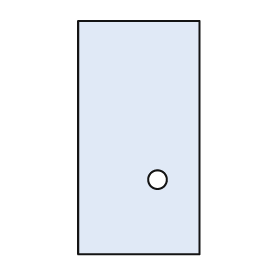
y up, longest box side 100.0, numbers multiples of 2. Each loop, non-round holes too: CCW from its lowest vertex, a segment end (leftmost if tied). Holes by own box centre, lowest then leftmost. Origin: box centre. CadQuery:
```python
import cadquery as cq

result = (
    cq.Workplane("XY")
    .moveTo(-26.0, -50.0)
    .lineTo(26.0, -50.0)
    .lineTo(26.0, 50.0)
    .lineTo(-26.0, 50.0)
    .close()
    .moveTo(8.0, -18.0)
    .circle(4.0)
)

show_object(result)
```